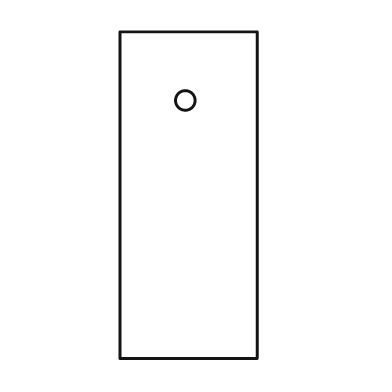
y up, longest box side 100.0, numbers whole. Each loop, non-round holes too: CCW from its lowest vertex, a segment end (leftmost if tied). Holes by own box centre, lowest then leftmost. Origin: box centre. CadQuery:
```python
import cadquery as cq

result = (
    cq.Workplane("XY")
    .moveTo(-21.0, -50.0)
    .lineTo(21.0, -50.0)
    .lineTo(21.0, 50.0)
    .lineTo(-21.0, 50.0)
    .close()
    .moveTo(-1.0, 29.0)
    .circle(3.0)
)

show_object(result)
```